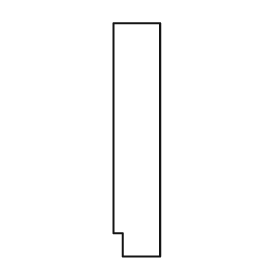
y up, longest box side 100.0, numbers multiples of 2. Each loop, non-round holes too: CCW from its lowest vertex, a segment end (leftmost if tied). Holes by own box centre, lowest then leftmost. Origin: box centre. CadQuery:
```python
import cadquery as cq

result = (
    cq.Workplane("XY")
    .moveTo(-6.0, -50.0)
    .lineTo(10.0, -50.0)
    .lineTo(10.0, 50.0)
    .lineTo(-10.0, 50.0)
    .lineTo(-10.0, -40.0)
    .lineTo(-6.0, -40.0)
    .close()
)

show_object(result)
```